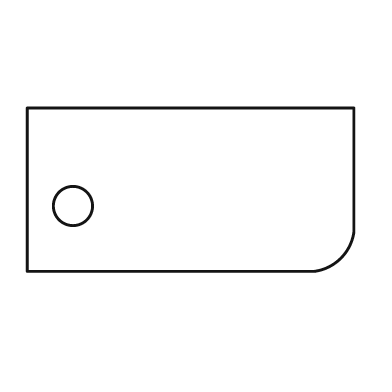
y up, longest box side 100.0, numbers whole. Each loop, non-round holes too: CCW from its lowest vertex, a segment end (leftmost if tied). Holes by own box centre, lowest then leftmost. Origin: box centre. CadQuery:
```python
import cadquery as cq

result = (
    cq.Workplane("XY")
    .moveTo(-50.0, -25.0)
    .lineTo(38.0, -25.0)
    .threePointArc((46.0, -21.0), (50.0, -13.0))
    .lineTo(50.0, 25.0)
    .lineTo(-50.0, 25.0)
    .close()
    .moveTo(-36.0, -5.0)
    .circle(6.0)
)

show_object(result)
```